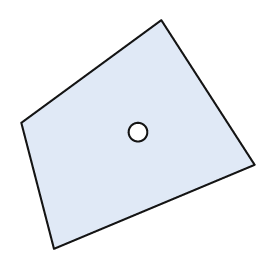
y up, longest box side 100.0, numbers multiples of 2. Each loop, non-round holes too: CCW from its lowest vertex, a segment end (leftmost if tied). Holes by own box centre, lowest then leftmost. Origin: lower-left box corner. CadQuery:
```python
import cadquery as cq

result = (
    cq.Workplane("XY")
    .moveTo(14.0, 0.0)
    .lineTo(100.0, 36.0)
    .lineTo(60.0, 98.0)
    .lineTo(0.0, 54.0)
    .close()
    .moveTo(50.0, 50.0)
    .circle(4.0)
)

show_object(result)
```